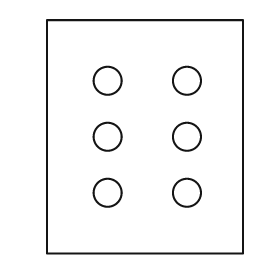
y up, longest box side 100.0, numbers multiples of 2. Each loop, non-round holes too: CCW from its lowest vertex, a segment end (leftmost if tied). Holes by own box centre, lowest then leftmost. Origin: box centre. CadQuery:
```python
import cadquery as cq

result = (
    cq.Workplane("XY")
    .moveTo(-42.0, -50.0)
    .lineTo(42.0, -50.0)
    .lineTo(42.0, 50.0)
    .lineTo(-42.0, 50.0)
    .close()
    .moveTo(-16.0, -24.0)
    .circle(6.0)
    .moveTo(18.0, -24.0)
    .circle(6.0)
    .moveTo(-16.0, 0.0)
    .circle(6.0)
    .moveTo(18.0, 0.0)
    .circle(6.0)
    .moveTo(-16.0, 24.0)
    .circle(6.0)
    .moveTo(18.0, 24.0)
    .circle(6.0)
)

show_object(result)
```